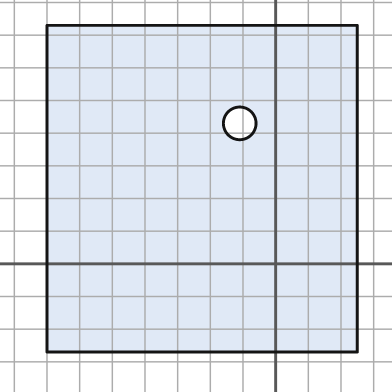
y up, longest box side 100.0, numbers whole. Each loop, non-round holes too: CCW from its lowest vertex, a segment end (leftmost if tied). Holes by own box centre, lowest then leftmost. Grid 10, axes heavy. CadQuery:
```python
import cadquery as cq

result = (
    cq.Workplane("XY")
    .moveTo(-70.0, -27.0)
    .lineTo(25.0, -27.0)
    .lineTo(25.0, 73.0)
    .lineTo(-70.0, 73.0)
    .close()
    .moveTo(-11.0, 43.0)
    .circle(5.0)
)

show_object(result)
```